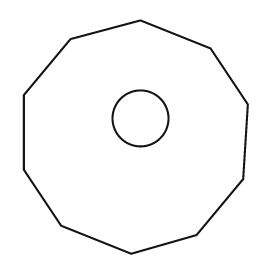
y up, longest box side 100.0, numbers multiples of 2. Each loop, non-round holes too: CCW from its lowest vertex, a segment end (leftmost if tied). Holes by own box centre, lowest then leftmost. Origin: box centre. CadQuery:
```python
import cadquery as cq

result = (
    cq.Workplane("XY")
    .moveTo(-2.0, -50.0)
    .lineTo(26.0, -42.0)
    .lineTo(46.0, -18.0)
    .lineTo(48.0, 14.0)
    .lineTo(32.0, 38.0)
    .lineTo(2.0, 50.0)
    .lineTo(-28.0, 42.0)
    .lineTo(-48.0, 18.0)
    .lineTo(-48.0, -14.0)
    .lineTo(-32.0, -38.0)
    .close()
    .moveTo(2.0, 8.0)
    .circle(12.0)
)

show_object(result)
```